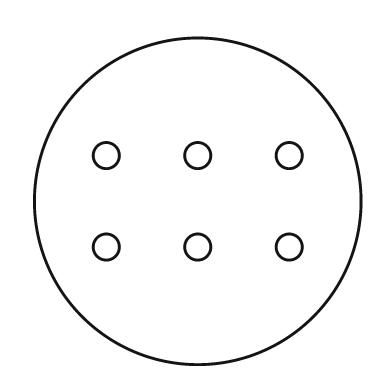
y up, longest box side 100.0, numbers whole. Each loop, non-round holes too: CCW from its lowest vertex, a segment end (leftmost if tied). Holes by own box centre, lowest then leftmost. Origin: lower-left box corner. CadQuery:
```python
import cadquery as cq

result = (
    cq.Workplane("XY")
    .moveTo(50.0, 50.0)
    .circle(50.0)
    .moveTo(22.0, 36.0)
    .circle(4.0)
    .moveTo(50.0, 36.0)
    .circle(4.0)
    .moveTo(78.0, 36.0)
    .circle(4.0)
    .moveTo(22.0, 64.0)
    .circle(4.0)
    .moveTo(50.0, 64.0)
    .circle(4.0)
    .moveTo(78.0, 64.0)
    .circle(4.0)
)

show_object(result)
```